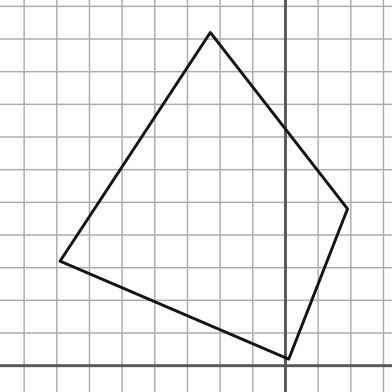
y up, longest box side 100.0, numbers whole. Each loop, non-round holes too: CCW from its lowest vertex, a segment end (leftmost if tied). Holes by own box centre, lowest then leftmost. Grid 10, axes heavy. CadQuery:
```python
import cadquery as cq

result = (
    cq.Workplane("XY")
    .moveTo(1.0, 2.0)
    .lineTo(19.0, 48.0)
    .lineTo(-23.0, 102.0)
    .lineTo(-69.0, 32.0)
    .close()
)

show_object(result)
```